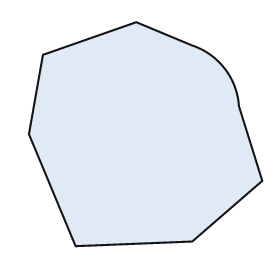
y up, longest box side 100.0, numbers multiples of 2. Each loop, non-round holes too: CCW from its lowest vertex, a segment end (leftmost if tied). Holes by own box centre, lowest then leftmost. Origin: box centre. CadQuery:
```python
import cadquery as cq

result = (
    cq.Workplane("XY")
    .moveTo(-30.0, -48.0)
    .lineTo(20.0, -46.0)
    .lineTo(50.0, -20.0)
    .lineTo(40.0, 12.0)
    .threePointArc((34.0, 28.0), (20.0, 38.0))
    .lineTo(-4.0, 48.0)
    .lineTo(-44.0, 34.0)
    .lineTo(-50.0, 0.0)
    .close()
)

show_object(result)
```